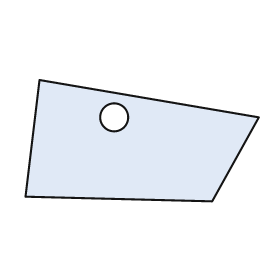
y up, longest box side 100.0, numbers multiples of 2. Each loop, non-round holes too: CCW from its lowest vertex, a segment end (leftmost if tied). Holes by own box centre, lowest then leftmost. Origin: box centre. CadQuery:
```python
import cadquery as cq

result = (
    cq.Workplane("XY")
    .moveTo(30.0, -26.0)
    .lineTo(50.0, 10.0)
    .lineTo(-44.0, 26.0)
    .lineTo(-50.0, -24.0)
    .close()
    .moveTo(-12.0, 10.0)
    .circle(6.0)
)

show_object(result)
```